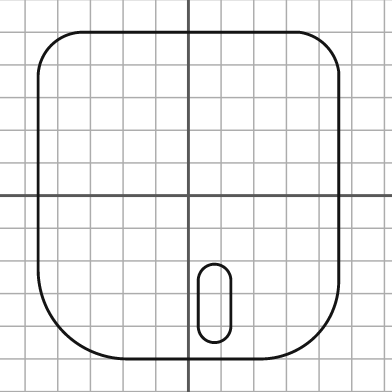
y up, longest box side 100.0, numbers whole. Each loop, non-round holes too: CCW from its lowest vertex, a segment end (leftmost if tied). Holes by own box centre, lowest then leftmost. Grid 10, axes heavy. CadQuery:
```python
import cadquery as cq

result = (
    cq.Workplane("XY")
    .moveTo(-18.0, -50.0)
    .lineTo(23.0, -50.0)
    .threePointArc((39.0, -43.0), (46.0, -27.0))
    .lineTo(46.0, 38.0)
    .threePointArc((42.0, 46.0), (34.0, 50.0))
    .lineTo(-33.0, 50.0)
    .threePointArc((-42.0, 46.0), (-46.0, 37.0))
    .lineTo(-46.0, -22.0)
    .threePointArc((-38.0, -42.0), (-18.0, -50.0))
    .close()
    .moveTo(3.0, -40.0)
    .threePointArc((8.0, -45.0), (13.0, -40.0))
    .lineTo(13.0, -26.0)
    .threePointArc((8.0, -21.0), (3.0, -26.0))
    .close()
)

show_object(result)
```